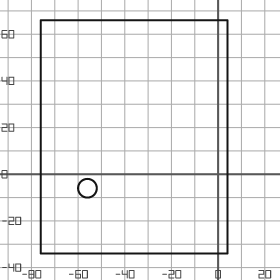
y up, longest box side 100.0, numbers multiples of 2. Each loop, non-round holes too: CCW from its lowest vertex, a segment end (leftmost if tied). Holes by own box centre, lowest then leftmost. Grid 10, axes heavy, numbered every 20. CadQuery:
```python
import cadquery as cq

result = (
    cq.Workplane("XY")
    .moveTo(-76.0, -34.0)
    .lineTo(4.0, -34.0)
    .lineTo(4.0, 66.0)
    .lineTo(-76.0, 66.0)
    .close()
    .moveTo(-56.0, -6.0)
    .circle(4.0)
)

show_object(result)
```